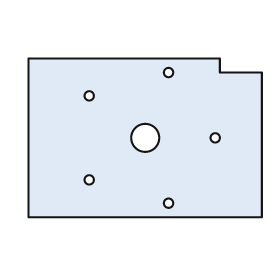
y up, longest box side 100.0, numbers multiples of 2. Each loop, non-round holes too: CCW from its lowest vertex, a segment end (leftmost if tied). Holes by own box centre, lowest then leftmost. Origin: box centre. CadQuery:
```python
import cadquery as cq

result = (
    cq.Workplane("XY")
    .moveTo(-50.0, -34.0)
    .lineTo(50.0, -34.0)
    .lineTo(50.0, 28.0)
    .lineTo(32.0, 28.0)
    .lineTo(32.0, 34.0)
    .lineTo(-50.0, 34.0)
    .close()
    .moveTo(10.0, -28.0)
    .circle(2.0)
    .moveTo(-24.0, -18.0)
    .circle(2.0)
    .moveTo(0.0, 0.0)
    .circle(6.0)
    .moveTo(30.0, 0.0)
    .circle(2.0)
    .moveTo(-24.0, 18.0)
    .circle(2.0)
    .moveTo(10.0, 28.0)
    .circle(2.0)
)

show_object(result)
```